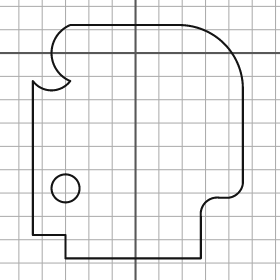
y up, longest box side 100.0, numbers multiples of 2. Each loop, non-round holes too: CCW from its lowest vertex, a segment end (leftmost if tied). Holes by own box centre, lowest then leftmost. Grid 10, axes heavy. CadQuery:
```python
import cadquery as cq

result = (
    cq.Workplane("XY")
    .moveTo(-30.0, -88.0)
    .lineTo(28.0, -88.0)
    .lineTo(28.0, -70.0)
    .threePointArc((30.0, -64.0), (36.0, -62.0))
    .lineTo(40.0, -62.0)
    .threePointArc((44.0, -60.0), (46.0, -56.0))
    .lineTo(46.0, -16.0)
    .threePointArc((38.0, 4.0), (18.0, 12.0))
    .lineTo(-28.0, 12.0)
    .threePointArc((-36.0, 0.0), (-28.0, -12.0))
    .threePointArc((-36.0, -16.0), (-44.0, -12.0))
    .lineTo(-44.0, -78.0)
    .lineTo(-30.0, -78.0)
    .close()
    .moveTo(-30.0, -58.0)
    .circle(6.0)
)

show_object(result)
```